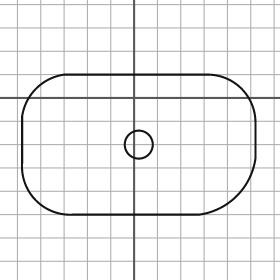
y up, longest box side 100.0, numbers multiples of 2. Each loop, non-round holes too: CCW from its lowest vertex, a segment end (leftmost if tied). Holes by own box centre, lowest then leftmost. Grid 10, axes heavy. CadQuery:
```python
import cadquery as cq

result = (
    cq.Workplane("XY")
    .moveTo(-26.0, -50.0)
    .lineTo(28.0, -50.0)
    .threePointArc((44.0, -42.0), (52.0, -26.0))
    .lineTo(52.0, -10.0)
    .threePointArc((46.0, 4.0), (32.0, 10.0))
    .lineTo(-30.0, 10.0)
    .threePointArc((-42.0, 4.0), (-48.0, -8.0))
    .lineTo(-48.0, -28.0)
    .threePointArc((-42.0, -44.0), (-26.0, -50.0))
    .close()
    .moveTo(2.0, -20.0)
    .circle(6.0)
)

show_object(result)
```